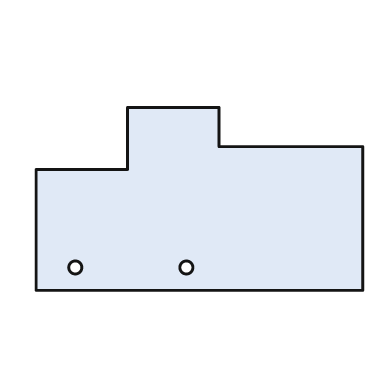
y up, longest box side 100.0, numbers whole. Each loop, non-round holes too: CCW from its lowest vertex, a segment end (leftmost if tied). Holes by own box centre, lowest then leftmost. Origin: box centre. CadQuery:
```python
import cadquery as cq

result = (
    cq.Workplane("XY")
    .moveTo(-50.0, -28.0)
    .lineTo(50.0, -28.0)
    .lineTo(50.0, 16.0)
    .lineTo(6.0, 16.0)
    .lineTo(6.0, 28.0)
    .lineTo(-22.0, 28.0)
    .lineTo(-22.0, 9.0)
    .lineTo(-50.0, 9.0)
    .close()
    .moveTo(-38.0, -21.0)
    .circle(2.0)
    .moveTo(-4.0, -21.0)
    .circle(2.0)
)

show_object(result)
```